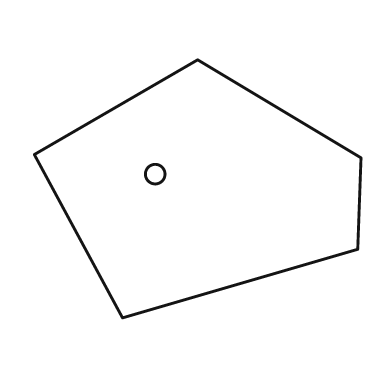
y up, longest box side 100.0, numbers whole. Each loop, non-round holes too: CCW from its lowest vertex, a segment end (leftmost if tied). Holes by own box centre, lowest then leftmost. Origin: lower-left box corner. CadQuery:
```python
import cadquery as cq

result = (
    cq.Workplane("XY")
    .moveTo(27.0, 0.0)
    .lineTo(99.0, 21.0)
    .lineTo(100.0, 49.0)
    .lineTo(50.0, 79.0)
    .lineTo(0.0, 50.0)
    .close()
    .moveTo(37.0, 44.0)
    .circle(3.0)
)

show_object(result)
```